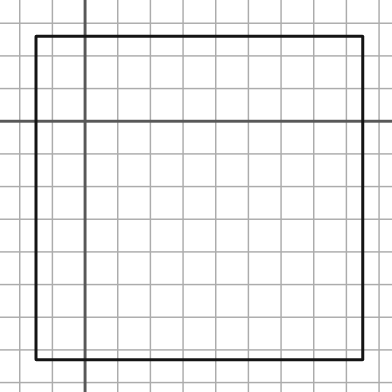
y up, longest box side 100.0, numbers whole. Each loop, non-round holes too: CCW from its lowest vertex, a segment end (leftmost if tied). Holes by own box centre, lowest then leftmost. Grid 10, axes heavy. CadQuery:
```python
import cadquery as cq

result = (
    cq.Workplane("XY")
    .moveTo(-15.0, -73.0)
    .lineTo(85.0, -73.0)
    .lineTo(85.0, 26.0)
    .lineTo(-15.0, 26.0)
    .close()
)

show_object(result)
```